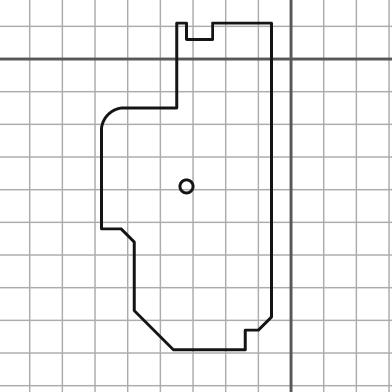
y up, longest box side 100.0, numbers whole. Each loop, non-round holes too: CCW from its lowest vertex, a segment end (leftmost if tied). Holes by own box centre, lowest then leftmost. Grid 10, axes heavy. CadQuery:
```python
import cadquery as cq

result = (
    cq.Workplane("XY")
    .moveTo(-36.0, -89.0)
    .lineTo(-14.0, -89.0)
    .lineTo(-14.0, -83.0)
    .lineTo(-10.0, -83.0)
    .lineTo(-6.0, -79.0)
    .lineTo(-6.0, 11.0)
    .lineTo(-24.0, 11.0)
    .lineTo(-24.0, 6.0)
    .lineTo(-32.0, 6.0)
    .lineTo(-32.0, 11.0)
    .lineTo(-35.0, 11.0)
    .lineTo(-35.0, -15.0)
    .lineTo(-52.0, -15.0)
    .threePointArc((-56.0, -17.0), (-58.0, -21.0))
    .lineTo(-58.0, -52.0)
    .lineTo(-52.0, -52.0)
    .lineTo(-48.0, -56.0)
    .lineTo(-48.0, -77.0)
    .close()
    .moveTo(-32.0, -39.0)
    .circle(2.0)
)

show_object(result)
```